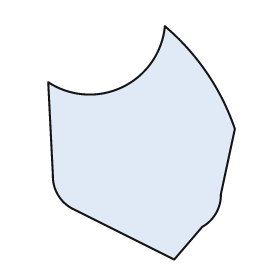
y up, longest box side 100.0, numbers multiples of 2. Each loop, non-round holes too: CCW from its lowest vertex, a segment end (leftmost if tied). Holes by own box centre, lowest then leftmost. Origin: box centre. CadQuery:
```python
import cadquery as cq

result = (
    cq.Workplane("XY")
    .moveTo(14.0, -50.0)
    .lineTo(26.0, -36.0)
    .threePointArc((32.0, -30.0), (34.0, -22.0))
    .lineTo(40.0, 6.0)
    .threePointArc((28.0, 30.0), (10.0, 50.0))
    .threePointArc((-8.0, 24.0), (-40.0, 26.0))
    .lineTo(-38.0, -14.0)
    .threePointArc((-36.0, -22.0), (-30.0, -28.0))
    .close()
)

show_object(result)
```